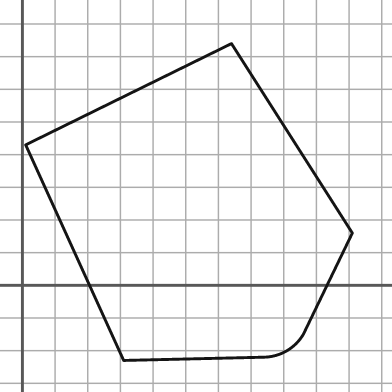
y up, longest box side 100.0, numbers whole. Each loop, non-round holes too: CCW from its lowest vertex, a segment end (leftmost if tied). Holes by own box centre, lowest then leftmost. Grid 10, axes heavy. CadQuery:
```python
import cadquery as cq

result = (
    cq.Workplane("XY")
    .moveTo(31.0, -23.0)
    .lineTo(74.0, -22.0)
    .threePointArc((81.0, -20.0), (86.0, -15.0))
    .lineTo(101.0, 16.0)
    .lineTo(64.0, 74.0)
    .lineTo(1.0, 43.0)
    .close()
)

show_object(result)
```